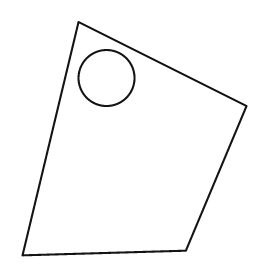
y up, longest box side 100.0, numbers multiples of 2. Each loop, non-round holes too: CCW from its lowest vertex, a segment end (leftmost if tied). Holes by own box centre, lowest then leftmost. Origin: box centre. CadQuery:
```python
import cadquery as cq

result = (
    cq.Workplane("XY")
    .moveTo(-48.0, -50.0)
    .lineTo(22.0, -48.0)
    .lineTo(48.0, 14.0)
    .lineTo(-24.0, 50.0)
    .close()
    .moveTo(-12.0, 26.0)
    .circle(12.0)
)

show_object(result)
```